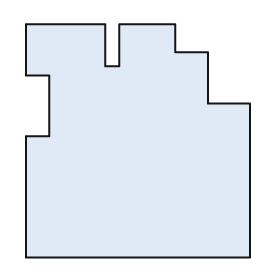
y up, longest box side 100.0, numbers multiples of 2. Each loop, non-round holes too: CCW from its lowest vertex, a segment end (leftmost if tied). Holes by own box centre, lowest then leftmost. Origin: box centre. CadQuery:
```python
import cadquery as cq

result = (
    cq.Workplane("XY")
    .moveTo(-48.0, -50.0)
    .lineTo(48.0, -50.0)
    .lineTo(48.0, 16.0)
    .lineTo(30.0, 16.0)
    .lineTo(30.0, 38.0)
    .lineTo(16.0, 38.0)
    .lineTo(16.0, 50.0)
    .lineTo(-8.0, 50.0)
    .lineTo(-8.0, 32.0)
    .lineTo(-14.0, 32.0)
    .lineTo(-14.0, 50.0)
    .lineTo(-48.0, 50.0)
    .lineTo(-48.0, 28.0)
    .lineTo(-38.0, 28.0)
    .lineTo(-38.0, 2.0)
    .lineTo(-48.0, 2.0)
    .close()
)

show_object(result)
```